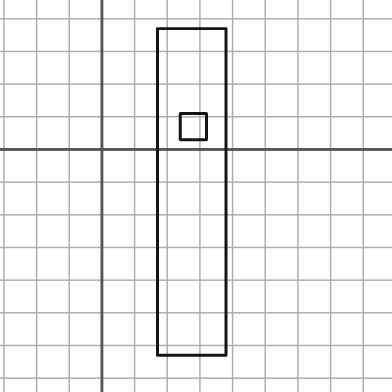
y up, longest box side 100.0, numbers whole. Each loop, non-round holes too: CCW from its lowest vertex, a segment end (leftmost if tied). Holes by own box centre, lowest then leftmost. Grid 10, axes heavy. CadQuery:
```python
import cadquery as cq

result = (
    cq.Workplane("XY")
    .moveTo(17.0, -63.0)
    .lineTo(38.0, -63.0)
    .lineTo(38.0, 37.0)
    .lineTo(17.0, 37.0)
    .close()
    .moveTo(24.0, 3.0)
    .lineTo(32.0, 3.0)
    .lineTo(32.0, 11.0)
    .lineTo(24.0, 11.0)
    .close()
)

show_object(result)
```